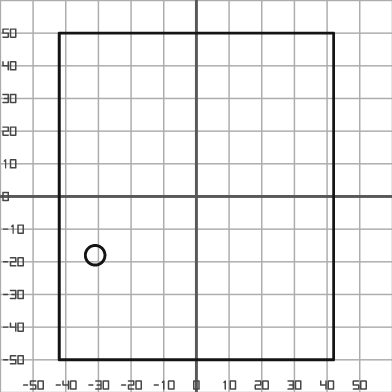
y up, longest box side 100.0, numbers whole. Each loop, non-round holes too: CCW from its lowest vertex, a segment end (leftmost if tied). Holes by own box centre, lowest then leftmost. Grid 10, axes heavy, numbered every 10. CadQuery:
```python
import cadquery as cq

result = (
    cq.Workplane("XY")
    .moveTo(-42.0, -50.0)
    .lineTo(42.0, -50.0)
    .lineTo(42.0, 50.0)
    .lineTo(-42.0, 50.0)
    .close()
    .moveTo(-31.0, -18.0)
    .circle(3.0)
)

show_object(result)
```